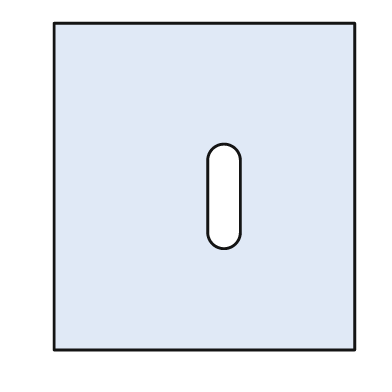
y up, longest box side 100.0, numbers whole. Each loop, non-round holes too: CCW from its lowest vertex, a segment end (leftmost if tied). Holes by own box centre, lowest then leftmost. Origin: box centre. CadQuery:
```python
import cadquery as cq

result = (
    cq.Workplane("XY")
    .moveTo(-46.0, -50.0)
    .lineTo(46.0, -50.0)
    .lineTo(46.0, 50.0)
    .lineTo(-46.0, 50.0)
    .close()
    .moveTo(1.0, -14.0)
    .threePointArc((6.0, -19.0), (11.0, -14.0))
    .lineTo(11.0, 8.0)
    .threePointArc((6.0, 13.0), (1.0, 8.0))
    .close()
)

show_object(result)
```